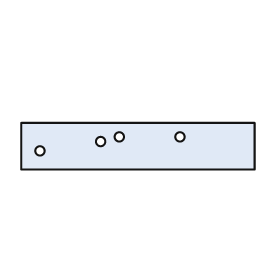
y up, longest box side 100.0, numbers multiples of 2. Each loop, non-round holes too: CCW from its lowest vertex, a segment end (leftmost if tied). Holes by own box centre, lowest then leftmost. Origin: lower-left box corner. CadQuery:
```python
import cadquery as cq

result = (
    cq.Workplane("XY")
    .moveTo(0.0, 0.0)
    .lineTo(100.0, 0.0)
    .lineTo(100.0, 20.0)
    .lineTo(0.0, 20.0)
    .close()
    .moveTo(8.0, 8.0)
    .circle(2.0)
    .moveTo(34.0, 12.0)
    .circle(2.0)
    .moveTo(42.0, 14.0)
    .circle(2.0)
    .moveTo(68.0, 14.0)
    .circle(2.0)
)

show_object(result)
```